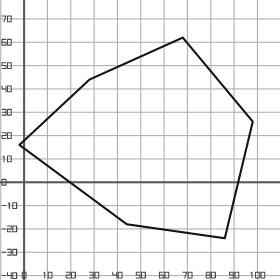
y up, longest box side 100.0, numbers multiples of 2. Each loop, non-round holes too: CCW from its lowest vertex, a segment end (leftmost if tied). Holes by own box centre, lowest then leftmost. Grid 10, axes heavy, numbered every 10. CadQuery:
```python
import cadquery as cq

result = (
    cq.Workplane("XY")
    .moveTo(86.0, -24.0)
    .lineTo(98.0, 26.0)
    .lineTo(68.0, 62.0)
    .lineTo(28.0, 44.0)
    .lineTo(-2.0, 16.0)
    .lineTo(44.0, -18.0)
    .close()
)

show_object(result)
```